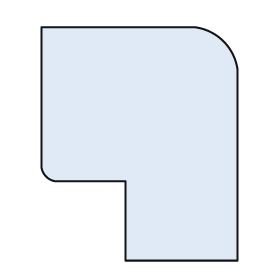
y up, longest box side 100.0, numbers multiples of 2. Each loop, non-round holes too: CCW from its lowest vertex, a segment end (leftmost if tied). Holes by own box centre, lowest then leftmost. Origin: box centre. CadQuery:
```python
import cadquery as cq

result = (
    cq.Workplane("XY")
    .moveTo(-6.0, -50.0)
    .lineTo(42.0, -50.0)
    .lineTo(42.0, 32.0)
    .threePointArc((36.0, 44.0), (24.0, 50.0))
    .lineTo(-42.0, 50.0)
    .lineTo(-42.0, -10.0)
    .threePointArc((-40.0, -14.0), (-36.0, -16.0))
    .lineTo(-6.0, -16.0)
    .close()
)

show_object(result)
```